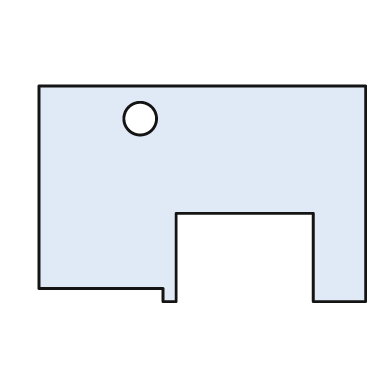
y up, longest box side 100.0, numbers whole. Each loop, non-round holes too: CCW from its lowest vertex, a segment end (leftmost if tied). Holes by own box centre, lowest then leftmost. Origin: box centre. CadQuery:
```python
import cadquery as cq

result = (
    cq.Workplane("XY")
    .moveTo(-12.0, -33.0)
    .lineTo(-8.0, -33.0)
    .lineTo(-8.0, -6.0)
    .lineTo(34.0, -6.0)
    .lineTo(34.0, -33.0)
    .lineTo(50.0, -33.0)
    .lineTo(50.0, 33.0)
    .lineTo(-50.0, 33.0)
    .lineTo(-50.0, -29.0)
    .lineTo(-12.0, -29.0)
    .close()
    .moveTo(-19.0, 23.0)
    .circle(5.0)
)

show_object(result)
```